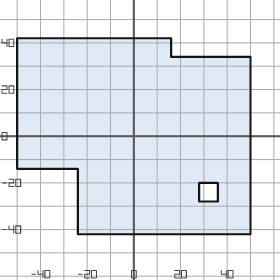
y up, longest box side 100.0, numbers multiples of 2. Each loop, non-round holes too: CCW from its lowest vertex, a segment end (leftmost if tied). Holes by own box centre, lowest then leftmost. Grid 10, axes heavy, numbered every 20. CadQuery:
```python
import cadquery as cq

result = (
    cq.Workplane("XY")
    .moveTo(-24.0, -42.0)
    .lineTo(50.0, -42.0)
    .lineTo(50.0, 34.0)
    .lineTo(16.0, 34.0)
    .lineTo(16.0, 42.0)
    .lineTo(-50.0, 42.0)
    .lineTo(-50.0, -14.0)
    .lineTo(-24.0, -14.0)
    .close()
    .moveTo(28.0, -28.0)
    .lineTo(36.0, -28.0)
    .lineTo(36.0, -20.0)
    .lineTo(28.0, -20.0)
    .close()
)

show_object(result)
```